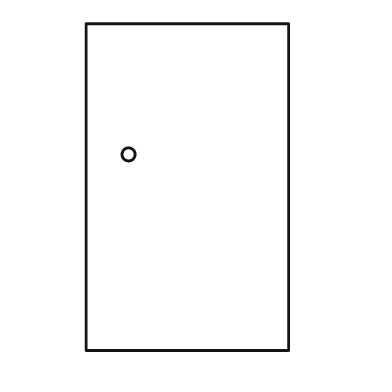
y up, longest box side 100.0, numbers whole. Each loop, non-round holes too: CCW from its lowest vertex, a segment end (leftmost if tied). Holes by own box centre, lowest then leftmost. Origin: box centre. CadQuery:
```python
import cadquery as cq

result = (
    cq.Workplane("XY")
    .moveTo(-31.0, -50.0)
    .lineTo(31.0, -50.0)
    .lineTo(31.0, 50.0)
    .lineTo(-31.0, 50.0)
    .close()
    .moveTo(-18.0, 10.0)
    .circle(2.0)
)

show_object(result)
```